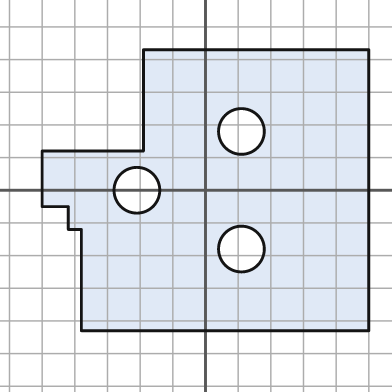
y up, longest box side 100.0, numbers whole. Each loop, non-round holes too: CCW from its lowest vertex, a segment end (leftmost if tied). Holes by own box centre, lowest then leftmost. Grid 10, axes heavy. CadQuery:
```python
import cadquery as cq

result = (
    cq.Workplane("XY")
    .moveTo(-38.0, -43.0)
    .lineTo(50.0, -43.0)
    .lineTo(50.0, 43.0)
    .lineTo(-19.0, 43.0)
    .lineTo(-19.0, 12.0)
    .lineTo(-50.0, 12.0)
    .lineTo(-50.0, -5.0)
    .lineTo(-42.0, -5.0)
    .lineTo(-42.0, -12.0)
    .lineTo(-38.0, -12.0)
    .close()
    .moveTo(11.0, -18.0)
    .circle(7.0)
    .moveTo(-21.0, 0.0)
    .circle(7.0)
    .moveTo(11.0, 18.0)
    .circle(7.0)
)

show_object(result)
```